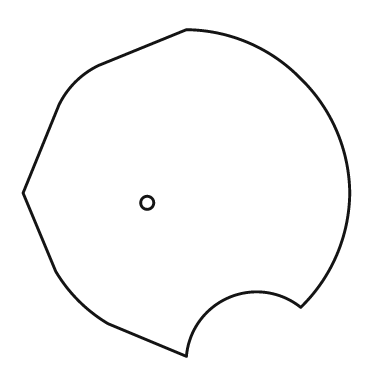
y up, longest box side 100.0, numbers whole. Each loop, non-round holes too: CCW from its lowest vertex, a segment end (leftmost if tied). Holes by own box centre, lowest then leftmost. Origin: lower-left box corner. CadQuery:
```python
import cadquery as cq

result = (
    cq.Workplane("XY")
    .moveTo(50.0, 0.0)
    .threePointArc((63.0, 18.0), (85.0, 15.0))
    .threePointArc((96.0, 31.0), (100.0, 50.0))
    .threePointArc((96.0, 69.0), (85.0, 85.0))
    .threePointArc((69.0, 96.0), (50.0, 100.0))
    .lineTo(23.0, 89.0)
    .threePointArc((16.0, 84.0), (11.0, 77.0))
    .lineTo(0.0, 50.0)
    .lineTo(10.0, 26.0)
    .threePointArc((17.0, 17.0), (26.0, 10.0))
    .close()
    .moveTo(38.0, 47.0)
    .circle(2.0)
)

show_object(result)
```